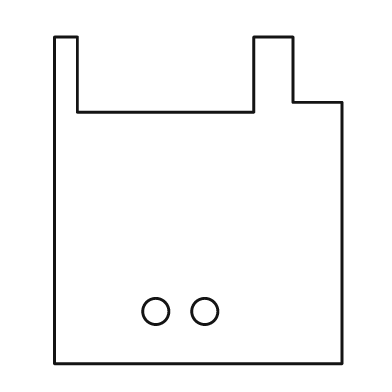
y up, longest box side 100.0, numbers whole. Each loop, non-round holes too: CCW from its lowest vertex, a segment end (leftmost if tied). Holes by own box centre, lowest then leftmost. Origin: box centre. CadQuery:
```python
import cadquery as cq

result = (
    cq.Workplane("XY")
    .moveTo(-44.0, -50.0)
    .lineTo(44.0, -50.0)
    .lineTo(44.0, 30.0)
    .lineTo(29.0, 30.0)
    .lineTo(29.0, 50.0)
    .lineTo(17.0, 50.0)
    .lineTo(17.0, 27.0)
    .lineTo(-37.0, 27.0)
    .lineTo(-37.0, 50.0)
    .lineTo(-44.0, 50.0)
    .close()
    .moveTo(-13.0, -34.0)
    .circle(4.0)
    .moveTo(2.0, -34.0)
    .circle(4.0)
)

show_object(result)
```